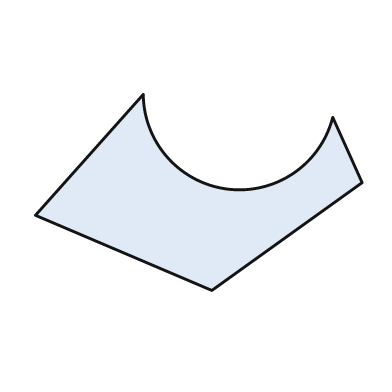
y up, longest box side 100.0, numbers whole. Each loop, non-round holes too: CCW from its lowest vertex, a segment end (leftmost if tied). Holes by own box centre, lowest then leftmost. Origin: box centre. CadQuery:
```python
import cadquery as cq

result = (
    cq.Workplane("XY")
    .moveTo(4.0, -30.0)
    .lineTo(50.0, 3.0)
    .lineTo(41.0, 23.0)
    .threePointArc((9.0, 1.0), (-17.0, 30.0))
    .lineTo(-50.0, -7.0)
    .close()
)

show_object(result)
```